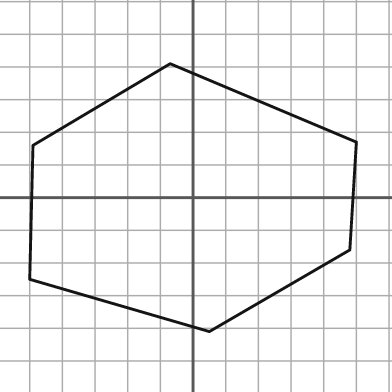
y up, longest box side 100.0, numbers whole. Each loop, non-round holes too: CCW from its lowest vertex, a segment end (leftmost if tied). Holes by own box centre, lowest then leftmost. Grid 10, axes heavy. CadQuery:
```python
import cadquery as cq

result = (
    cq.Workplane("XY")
    .moveTo(5.0, -41.0)
    .lineTo(48.0, -16.0)
    .lineTo(50.0, 17.0)
    .lineTo(-7.0, 41.0)
    .lineTo(-49.0, 16.0)
    .lineTo(-50.0, -25.0)
    .close()
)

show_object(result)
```